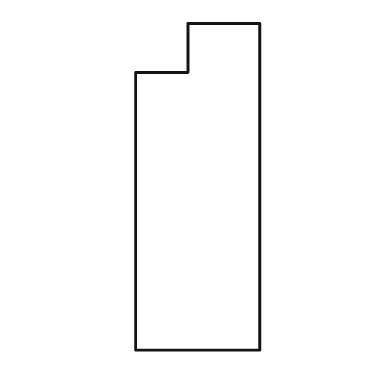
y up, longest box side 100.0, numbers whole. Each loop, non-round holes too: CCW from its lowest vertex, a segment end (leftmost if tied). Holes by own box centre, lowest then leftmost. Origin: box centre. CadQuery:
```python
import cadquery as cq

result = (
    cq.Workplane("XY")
    .moveTo(-19.0, -50.0)
    .lineTo(19.0, -50.0)
    .lineTo(19.0, 50.0)
    .lineTo(-3.0, 50.0)
    .lineTo(-3.0, 35.0)
    .lineTo(-19.0, 35.0)
    .close()
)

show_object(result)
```